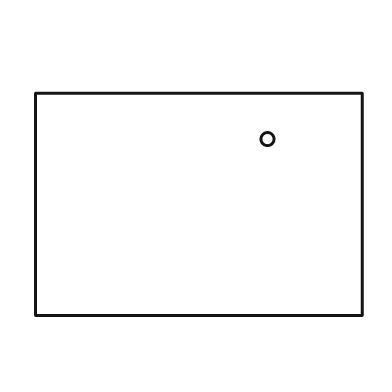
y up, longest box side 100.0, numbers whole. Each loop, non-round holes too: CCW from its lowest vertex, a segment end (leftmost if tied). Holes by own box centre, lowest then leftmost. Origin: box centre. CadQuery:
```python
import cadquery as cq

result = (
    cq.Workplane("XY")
    .moveTo(-50.0, -34.0)
    .lineTo(50.0, -34.0)
    .lineTo(50.0, 34.0)
    .lineTo(-50.0, 34.0)
    .close()
    .moveTo(21.0, 20.0)
    .circle(2.0)
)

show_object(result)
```